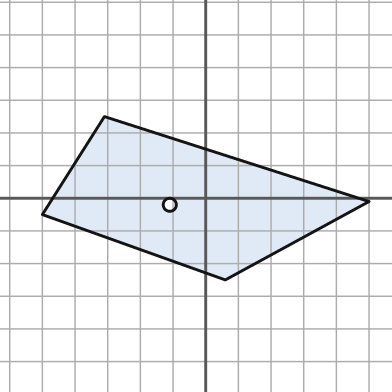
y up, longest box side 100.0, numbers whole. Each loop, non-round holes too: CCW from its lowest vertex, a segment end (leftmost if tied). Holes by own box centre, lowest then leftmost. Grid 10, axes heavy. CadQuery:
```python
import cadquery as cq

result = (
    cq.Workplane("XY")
    .moveTo(6.0, -25.0)
    .lineTo(50.0, -1.0)
    .lineTo(-31.0, 25.0)
    .lineTo(-50.0, -5.0)
    .close()
    .moveTo(-11.0, -2.0)
    .circle(2.0)
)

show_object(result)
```